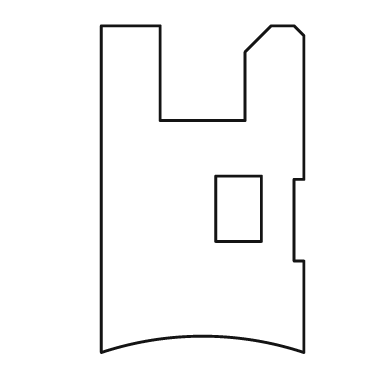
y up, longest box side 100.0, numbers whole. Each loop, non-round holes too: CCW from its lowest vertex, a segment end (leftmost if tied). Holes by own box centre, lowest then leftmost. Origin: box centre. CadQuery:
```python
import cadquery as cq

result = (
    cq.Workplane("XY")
    .moveTo(-31.0, -50.0)
    .threePointArc((0.0, -45.0), (31.0, -50.0))
    .lineTo(31.0, -22.0)
    .lineTo(28.0, -22.0)
    .lineTo(28.0, 3.0)
    .lineTo(31.0, 3.0)
    .lineTo(31.0, 47.0)
    .lineTo(28.0, 50.0)
    .lineTo(21.0, 50.0)
    .lineTo(13.0, 42.0)
    .lineTo(13.0, 21.0)
    .lineTo(-13.0, 21.0)
    .lineTo(-13.0, 50.0)
    .lineTo(-31.0, 50.0)
    .close()
    .moveTo(4.0, -16.0)
    .lineTo(18.0, -16.0)
    .lineTo(18.0, 4.0)
    .lineTo(4.0, 4.0)
    .close()
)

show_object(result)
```